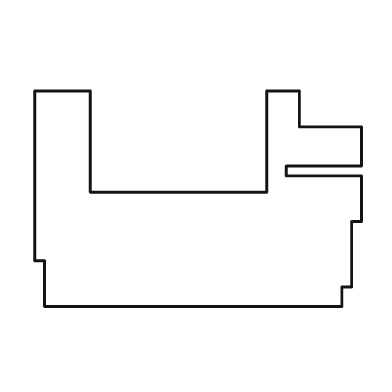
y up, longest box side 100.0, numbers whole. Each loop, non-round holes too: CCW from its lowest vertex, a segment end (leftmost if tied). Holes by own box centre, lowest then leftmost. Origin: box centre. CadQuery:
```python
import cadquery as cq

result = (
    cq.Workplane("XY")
    .moveTo(-47.0, -33.0)
    .lineTo(44.0, -33.0)
    .lineTo(44.0, -27.0)
    .lineTo(47.0, -27.0)
    .lineTo(47.0, -7.0)
    .lineTo(50.0, -7.0)
    .lineTo(50.0, 7.0)
    .lineTo(27.0, 7.0)
    .lineTo(27.0, 10.0)
    .lineTo(50.0, 10.0)
    .lineTo(50.0, 22.0)
    .lineTo(31.0, 22.0)
    .lineTo(31.0, 33.0)
    .lineTo(21.0, 33.0)
    .lineTo(21.0, 2.0)
    .lineTo(-33.0, 2.0)
    .lineTo(-33.0, 33.0)
    .lineTo(-50.0, 33.0)
    .lineTo(-50.0, -19.0)
    .lineTo(-47.0, -19.0)
    .close()
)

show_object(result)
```